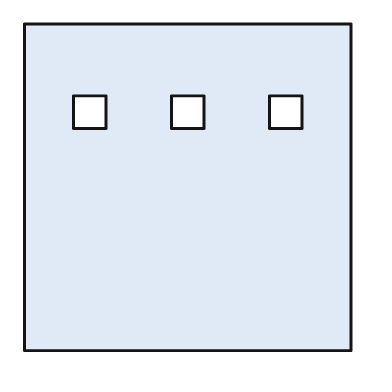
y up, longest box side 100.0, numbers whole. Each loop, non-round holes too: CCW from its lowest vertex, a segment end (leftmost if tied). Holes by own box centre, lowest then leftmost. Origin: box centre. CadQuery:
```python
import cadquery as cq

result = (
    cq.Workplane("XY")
    .moveTo(-50.0, -50.0)
    .lineTo(50.0, -50.0)
    .lineTo(50.0, 50.0)
    .lineTo(-50.0, 50.0)
    .close()
    .moveTo(-35.0, 18.0)
    .lineTo(-25.0, 18.0)
    .lineTo(-25.0, 28.0)
    .lineTo(-35.0, 28.0)
    .close()
    .moveTo(-5.0, 18.0)
    .lineTo(5.0, 18.0)
    .lineTo(5.0, 28.0)
    .lineTo(-5.0, 28.0)
    .close()
    .moveTo(25.0, 18.0)
    .lineTo(35.0, 18.0)
    .lineTo(35.0, 28.0)
    .lineTo(25.0, 28.0)
    .close()
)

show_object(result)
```